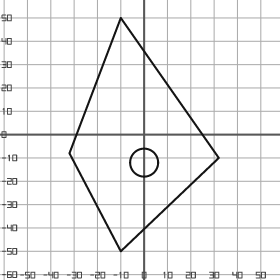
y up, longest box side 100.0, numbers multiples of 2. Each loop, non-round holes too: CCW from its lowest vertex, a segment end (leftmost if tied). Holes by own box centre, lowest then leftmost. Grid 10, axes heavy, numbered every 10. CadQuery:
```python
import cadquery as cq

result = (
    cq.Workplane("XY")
    .moveTo(-10.0, -50.0)
    .lineTo(32.0, -10.0)
    .lineTo(-10.0, 50.0)
    .lineTo(-32.0, -8.0)
    .close()
    .moveTo(0.0, -12.0)
    .circle(6.0)
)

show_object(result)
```